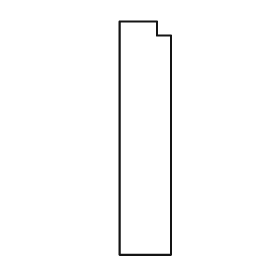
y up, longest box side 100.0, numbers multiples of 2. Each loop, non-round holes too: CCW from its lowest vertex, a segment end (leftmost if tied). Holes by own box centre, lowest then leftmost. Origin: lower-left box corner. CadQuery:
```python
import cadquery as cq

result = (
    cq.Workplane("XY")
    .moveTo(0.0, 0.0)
    .lineTo(22.0, 0.0)
    .lineTo(22.0, 94.0)
    .lineTo(16.0, 94.0)
    .lineTo(16.0, 100.0)
    .lineTo(0.0, 100.0)
    .close()
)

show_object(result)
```